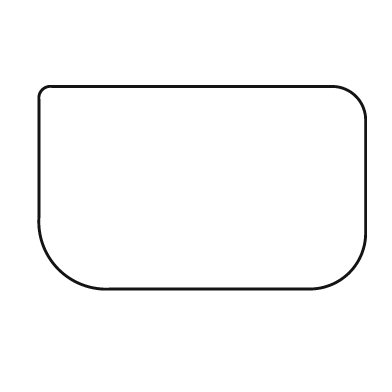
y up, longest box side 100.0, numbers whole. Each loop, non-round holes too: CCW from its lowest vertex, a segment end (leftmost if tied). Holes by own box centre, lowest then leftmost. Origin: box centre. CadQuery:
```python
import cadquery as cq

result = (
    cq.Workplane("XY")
    .moveTo(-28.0, -31.0)
    .lineTo(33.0, -31.0)
    .threePointArc((45.0, -26.0), (50.0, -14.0))
    .lineTo(50.0, 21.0)
    .threePointArc((47.0, 28.0), (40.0, 31.0))
    .lineTo(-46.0, 31.0)
    .threePointArc((-49.0, 30.0), (-50.0, 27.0))
    .lineTo(-50.0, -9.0)
    .threePointArc((-44.0, -25.0), (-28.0, -31.0))
    .close()
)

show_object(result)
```